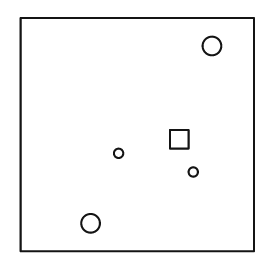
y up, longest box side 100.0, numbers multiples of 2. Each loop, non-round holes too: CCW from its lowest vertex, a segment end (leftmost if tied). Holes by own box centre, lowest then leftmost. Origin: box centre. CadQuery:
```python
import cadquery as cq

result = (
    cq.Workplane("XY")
    .moveTo(-50.0, -50.0)
    .lineTo(50.0, -50.0)
    .lineTo(50.0, 50.0)
    .lineTo(-50.0, 50.0)
    .close()
    .moveTo(-20.0, -38.0)
    .circle(4.0)
    .moveTo(24.0, -16.0)
    .circle(2.0)
    .moveTo(-8.0, -8.0)
    .circle(2.0)
    .moveTo(14.0, -6.0)
    .lineTo(22.0, -6.0)
    .lineTo(22.0, 2.0)
    .lineTo(14.0, 2.0)
    .close()
    .moveTo(32.0, 38.0)
    .circle(4.0)
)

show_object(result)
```